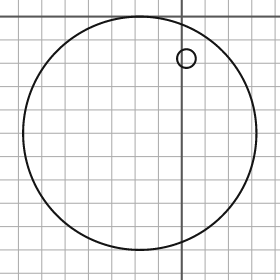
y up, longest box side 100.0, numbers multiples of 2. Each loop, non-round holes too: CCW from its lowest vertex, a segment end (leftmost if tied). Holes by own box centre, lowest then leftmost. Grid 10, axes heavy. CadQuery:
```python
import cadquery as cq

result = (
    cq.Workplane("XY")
    .moveTo(-18.0, -50.0)
    .circle(50.0)
    .moveTo(2.0, -18.0)
    .circle(4.0)
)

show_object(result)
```